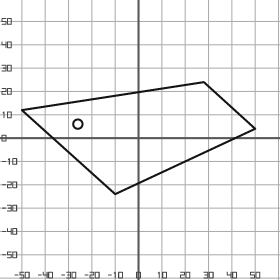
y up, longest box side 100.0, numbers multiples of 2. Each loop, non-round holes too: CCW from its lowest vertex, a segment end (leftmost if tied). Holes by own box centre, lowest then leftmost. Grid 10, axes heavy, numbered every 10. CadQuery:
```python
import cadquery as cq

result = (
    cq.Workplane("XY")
    .moveTo(-10.0, -24.0)
    .lineTo(50.0, 4.0)
    .lineTo(28.0, 24.0)
    .lineTo(-50.0, 12.0)
    .close()
    .moveTo(-26.0, 6.0)
    .circle(2.0)
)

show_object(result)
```